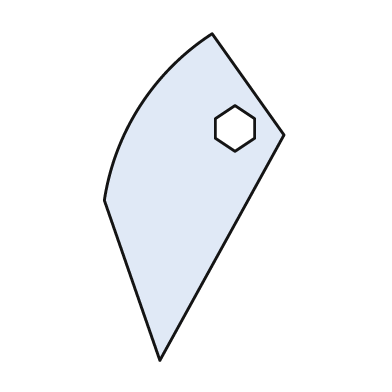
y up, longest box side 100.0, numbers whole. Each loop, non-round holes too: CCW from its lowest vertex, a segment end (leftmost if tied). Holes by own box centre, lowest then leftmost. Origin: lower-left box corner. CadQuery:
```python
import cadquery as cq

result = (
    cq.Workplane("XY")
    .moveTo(17.0, 0.0)
    .lineTo(55.0, 69.0)
    .lineTo(33.0, 100.0)
    .threePointArc((11.0, 78.0), (0.0, 49.0))
    .close()
    .moveTo(40.0, 64.0)
    .lineTo(46.0, 68.0)
    .lineTo(46.0, 74.0)
    .lineTo(40.0, 78.0)
    .lineTo(34.0, 74.0)
    .lineTo(34.0, 68.0)
    .close()
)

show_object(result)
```